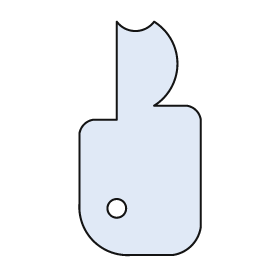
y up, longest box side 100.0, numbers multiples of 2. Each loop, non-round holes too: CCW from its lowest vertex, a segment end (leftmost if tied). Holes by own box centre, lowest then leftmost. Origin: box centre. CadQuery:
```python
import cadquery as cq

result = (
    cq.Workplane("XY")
    .moveTo(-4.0, -50.0)
    .lineTo(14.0, -50.0)
    .threePointArc((22.0, -46.0), (26.0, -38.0))
    .lineTo(26.0, 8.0)
    .threePointArc((24.0, 12.0), (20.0, 14.0))
    .lineTo(6.0, 14.0)
    .threePointArc((16.0, 32.0), (6.0, 50.0))
    .threePointArc((-2.0, 46.0), (-10.0, 50.0))
    .lineTo(-10.0, 8.0)
    .lineTo(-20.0, 8.0)
    .threePointArc((-24.0, 6.0), (-26.0, 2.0))
    .lineTo(-26.0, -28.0)
    .threePointArc((-20.0, -44.0), (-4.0, -50.0))
    .close()
    .moveTo(-10.0, -30.0)
    .circle(4.0)
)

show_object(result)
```